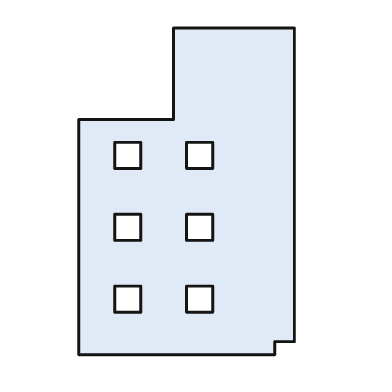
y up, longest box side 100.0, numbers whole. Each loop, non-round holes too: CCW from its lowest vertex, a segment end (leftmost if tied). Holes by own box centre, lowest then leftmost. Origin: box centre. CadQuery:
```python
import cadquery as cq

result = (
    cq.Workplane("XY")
    .moveTo(-33.0, -50.0)
    .lineTo(27.0, -50.0)
    .lineTo(27.0, -46.0)
    .lineTo(33.0, -46.0)
    .lineTo(33.0, 50.0)
    .lineTo(-4.0, 50.0)
    .lineTo(-4.0, 22.0)
    .lineTo(-33.0, 22.0)
    .close()
    .moveTo(-22.0, -37.0)
    .lineTo(-14.0, -37.0)
    .lineTo(-14.0, -29.0)
    .lineTo(-22.0, -29.0)
    .close()
    .moveTo(0.0, -37.0)
    .lineTo(8.0, -37.0)
    .lineTo(8.0, -29.0)
    .lineTo(0.0, -29.0)
    .close()
    .moveTo(-22.0, -15.0)
    .lineTo(-14.0, -15.0)
    .lineTo(-14.0, -7.0)
    .lineTo(-22.0, -7.0)
    .close()
    .moveTo(0.0, -15.0)
    .lineTo(8.0, -15.0)
    .lineTo(8.0, -7.0)
    .lineTo(0.0, -7.0)
    .close()
    .moveTo(-22.0, 7.0)
    .lineTo(-14.0, 7.0)
    .lineTo(-14.0, 15.0)
    .lineTo(-22.0, 15.0)
    .close()
    .moveTo(0.0, 7.0)
    .lineTo(8.0, 7.0)
    .lineTo(8.0, 15.0)
    .lineTo(0.0, 15.0)
    .close()
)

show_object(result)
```